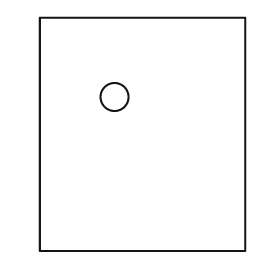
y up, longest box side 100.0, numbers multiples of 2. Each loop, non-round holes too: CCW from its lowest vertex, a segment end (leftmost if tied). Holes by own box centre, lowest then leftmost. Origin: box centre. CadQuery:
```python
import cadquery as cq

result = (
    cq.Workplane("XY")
    .moveTo(-44.0, -50.0)
    .lineTo(44.0, -50.0)
    .lineTo(44.0, 50.0)
    .lineTo(-44.0, 50.0)
    .close()
    .moveTo(-12.0, 16.0)
    .circle(6.0)
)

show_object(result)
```